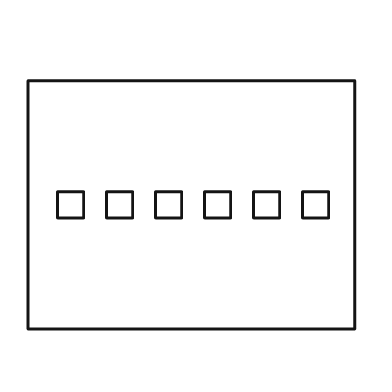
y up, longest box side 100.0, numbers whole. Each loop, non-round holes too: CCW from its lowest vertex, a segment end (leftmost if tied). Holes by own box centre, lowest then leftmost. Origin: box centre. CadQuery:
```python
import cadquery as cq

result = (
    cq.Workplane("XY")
    .moveTo(-50.0, -38.0)
    .lineTo(50.0, -38.0)
    .lineTo(50.0, 38.0)
    .lineTo(-50.0, 38.0)
    .close()
    .moveTo(-41.0, -4.0)
    .lineTo(-33.0, -4.0)
    .lineTo(-33.0, 4.0)
    .lineTo(-41.0, 4.0)
    .close()
    .moveTo(-26.0, -4.0)
    .lineTo(-18.0, -4.0)
    .lineTo(-18.0, 4.0)
    .lineTo(-26.0, 4.0)
    .close()
    .moveTo(-11.0, -4.0)
    .lineTo(-3.0, -4.0)
    .lineTo(-3.0, 4.0)
    .lineTo(-11.0, 4.0)
    .close()
    .moveTo(4.0, -4.0)
    .lineTo(12.0, -4.0)
    .lineTo(12.0, 4.0)
    .lineTo(4.0, 4.0)
    .close()
    .moveTo(19.0, -4.0)
    .lineTo(27.0, -4.0)
    .lineTo(27.0, 4.0)
    .lineTo(19.0, 4.0)
    .close()
    .moveTo(34.0, -4.0)
    .lineTo(42.0, -4.0)
    .lineTo(42.0, 4.0)
    .lineTo(34.0, 4.0)
    .close()
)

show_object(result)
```